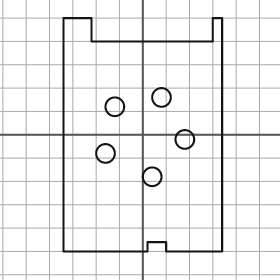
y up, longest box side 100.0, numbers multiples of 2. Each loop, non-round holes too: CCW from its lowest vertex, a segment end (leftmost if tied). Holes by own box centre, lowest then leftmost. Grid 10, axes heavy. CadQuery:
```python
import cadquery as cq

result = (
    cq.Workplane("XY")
    .moveTo(-34.0, -50.0)
    .lineTo(2.0, -50.0)
    .lineTo(2.0, -46.0)
    .lineTo(10.0, -46.0)
    .lineTo(10.0, -50.0)
    .lineTo(34.0, -50.0)
    .lineTo(34.0, 50.0)
    .lineTo(30.0, 50.0)
    .lineTo(30.0, 40.0)
    .lineTo(-22.0, 40.0)
    .lineTo(-22.0, 50.0)
    .lineTo(-34.0, 50.0)
    .close()
    .moveTo(4.0, -18.0)
    .circle(4.0)
    .moveTo(-16.0, -8.0)
    .circle(4.0)
    .moveTo(18.0, -2.0)
    .circle(4.0)
    .moveTo(-12.0, 12.0)
    .circle(4.0)
    .moveTo(8.0, 16.0)
    .circle(4.0)
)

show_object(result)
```